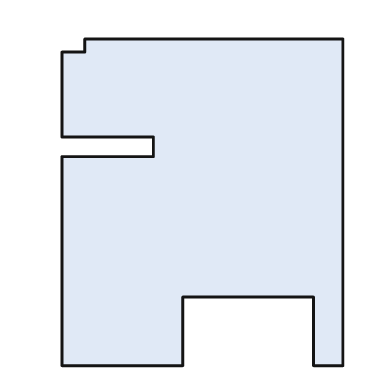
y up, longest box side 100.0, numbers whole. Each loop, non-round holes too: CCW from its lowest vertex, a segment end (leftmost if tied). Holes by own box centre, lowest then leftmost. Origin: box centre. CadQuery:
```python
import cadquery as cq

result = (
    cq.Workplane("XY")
    .moveTo(-43.0, -50.0)
    .lineTo(-6.0, -50.0)
    .lineTo(-6.0, -29.0)
    .lineTo(34.0, -29.0)
    .lineTo(34.0, -50.0)
    .lineTo(43.0, -50.0)
    .lineTo(43.0, 50.0)
    .lineTo(-36.0, 50.0)
    .lineTo(-36.0, 46.0)
    .lineTo(-43.0, 46.0)
    .lineTo(-43.0, 20.0)
    .lineTo(-15.0, 20.0)
    .lineTo(-15.0, 14.0)
    .lineTo(-43.0, 14.0)
    .close()
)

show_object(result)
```